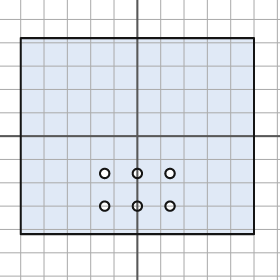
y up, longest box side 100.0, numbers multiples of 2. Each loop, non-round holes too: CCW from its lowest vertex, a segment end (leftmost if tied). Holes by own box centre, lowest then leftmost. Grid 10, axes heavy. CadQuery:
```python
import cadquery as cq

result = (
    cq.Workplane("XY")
    .moveTo(-50.0, -42.0)
    .lineTo(50.0, -42.0)
    .lineTo(50.0, 42.0)
    .lineTo(-50.0, 42.0)
    .close()
    .moveTo(-14.0, -30.0)
    .circle(2.0)
    .moveTo(0.0, -30.0)
    .circle(2.0)
    .moveTo(14.0, -30.0)
    .circle(2.0)
    .moveTo(-14.0, -16.0)
    .circle(2.0)
    .moveTo(0.0, -16.0)
    .circle(2.0)
    .moveTo(14.0, -16.0)
    .circle(2.0)
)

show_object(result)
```